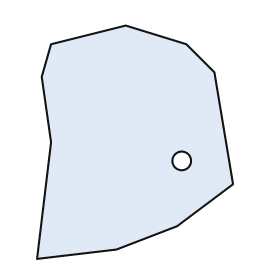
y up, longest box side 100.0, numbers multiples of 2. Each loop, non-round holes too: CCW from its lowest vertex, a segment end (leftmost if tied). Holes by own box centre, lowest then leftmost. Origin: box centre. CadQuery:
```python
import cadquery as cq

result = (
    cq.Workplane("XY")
    .moveTo(-42.0, -50.0)
    .lineTo(-8.0, -46.0)
    .lineTo(18.0, -36.0)
    .lineTo(42.0, -18.0)
    .lineTo(34.0, 30.0)
    .lineTo(22.0, 42.0)
    .lineTo(-4.0, 50.0)
    .lineTo(-36.0, 42.0)
    .lineTo(-40.0, 28.0)
    .lineTo(-36.0, 0.0)
    .close()
    .moveTo(20.0, -8.0)
    .circle(4.0)
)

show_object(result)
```